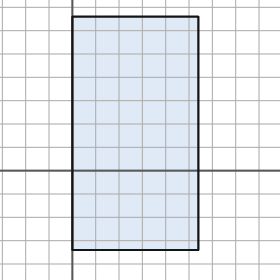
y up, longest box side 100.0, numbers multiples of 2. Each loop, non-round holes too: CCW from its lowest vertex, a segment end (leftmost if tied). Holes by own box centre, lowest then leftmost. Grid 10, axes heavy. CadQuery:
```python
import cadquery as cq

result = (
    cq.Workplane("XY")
    .moveTo(0.0, -34.0)
    .lineTo(54.0, -34.0)
    .lineTo(54.0, 66.0)
    .lineTo(0.0, 66.0)
    .close()
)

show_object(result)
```